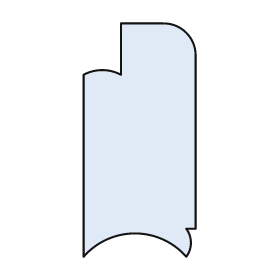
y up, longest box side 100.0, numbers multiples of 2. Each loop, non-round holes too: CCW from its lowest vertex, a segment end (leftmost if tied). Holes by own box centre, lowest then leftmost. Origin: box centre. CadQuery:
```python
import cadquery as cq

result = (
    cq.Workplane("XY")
    .moveTo(-24.0, -50.0)
    .threePointArc((-2.0, -40.0), (20.0, -50.0))
    .threePointArc((22.0, -44.0), (20.0, -38.0))
    .lineTo(24.0, -38.0)
    .lineTo(24.0, 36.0)
    .threePointArc((20.0, 46.0), (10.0, 50.0))
    .lineTo(-8.0, 50.0)
    .lineTo(-8.0, 28.0)
    .threePointArc((-16.0, 30.0), (-24.0, 28.0))
    .close()
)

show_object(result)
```